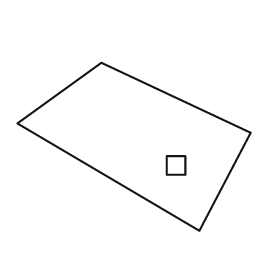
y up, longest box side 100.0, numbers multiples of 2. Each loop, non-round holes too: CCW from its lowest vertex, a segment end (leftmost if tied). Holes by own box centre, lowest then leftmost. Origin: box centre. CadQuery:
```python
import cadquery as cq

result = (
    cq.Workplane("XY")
    .moveTo(28.0, -36.0)
    .lineTo(50.0, 6.0)
    .lineTo(-14.0, 36.0)
    .lineTo(-50.0, 10.0)
    .close()
    .moveTo(14.0, -12.0)
    .lineTo(22.0, -12.0)
    .lineTo(22.0, -4.0)
    .lineTo(14.0, -4.0)
    .close()
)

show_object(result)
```